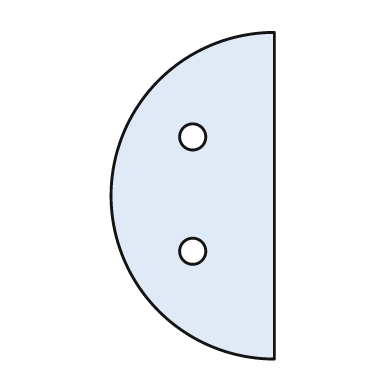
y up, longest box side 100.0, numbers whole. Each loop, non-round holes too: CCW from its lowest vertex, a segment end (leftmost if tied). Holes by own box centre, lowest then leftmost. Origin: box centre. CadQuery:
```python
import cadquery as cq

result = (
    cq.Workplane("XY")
    .moveTo(25.0, -50.0)
    .lineTo(25.0, 50.0)
    .threePointArc((-25.0, 0.0), (25.0, -50.0))
    .close()
    .moveTo(0.0, -17.0)
    .circle(4.0)
    .moveTo(0.0, 18.0)
    .circle(4.0)
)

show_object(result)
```